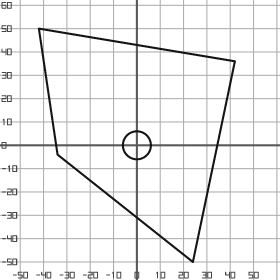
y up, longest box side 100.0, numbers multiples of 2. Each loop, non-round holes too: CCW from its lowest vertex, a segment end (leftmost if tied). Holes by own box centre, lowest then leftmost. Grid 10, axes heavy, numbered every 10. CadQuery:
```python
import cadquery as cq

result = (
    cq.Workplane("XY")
    .moveTo(24.0, -50.0)
    .lineTo(42.0, 36.0)
    .lineTo(-42.0, 50.0)
    .lineTo(-34.0, -4.0)
    .close()
    .moveTo(0.0, 0.0)
    .circle(6.0)
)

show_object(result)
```